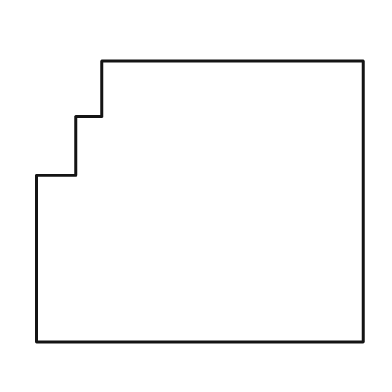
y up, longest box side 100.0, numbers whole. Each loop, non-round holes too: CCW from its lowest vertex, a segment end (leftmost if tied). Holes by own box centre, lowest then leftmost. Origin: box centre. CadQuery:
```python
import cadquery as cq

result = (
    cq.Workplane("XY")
    .moveTo(-50.0, -43.0)
    .lineTo(50.0, -43.0)
    .lineTo(50.0, 43.0)
    .lineTo(-30.0, 43.0)
    .lineTo(-30.0, 26.0)
    .lineTo(-38.0, 26.0)
    .lineTo(-38.0, 8.0)
    .lineTo(-50.0, 8.0)
    .close()
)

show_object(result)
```